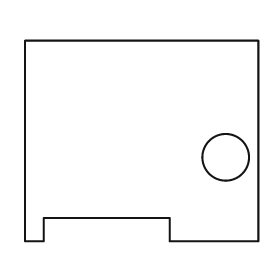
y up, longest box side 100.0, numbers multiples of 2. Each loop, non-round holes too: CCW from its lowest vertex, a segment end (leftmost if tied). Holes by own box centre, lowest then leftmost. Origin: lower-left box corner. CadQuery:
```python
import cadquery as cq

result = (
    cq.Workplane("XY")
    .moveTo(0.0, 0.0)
    .lineTo(8.0, 0.0)
    .lineTo(8.0, 10.0)
    .lineTo(62.0, 10.0)
    .lineTo(62.0, 0.0)
    .lineTo(100.0, 0.0)
    .lineTo(100.0, 86.0)
    .lineTo(0.0, 86.0)
    .close()
    .moveTo(86.0, 36.0)
    .circle(10.0)
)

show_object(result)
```